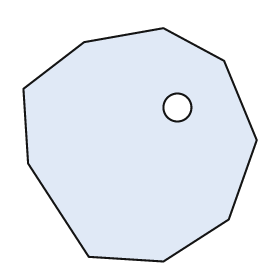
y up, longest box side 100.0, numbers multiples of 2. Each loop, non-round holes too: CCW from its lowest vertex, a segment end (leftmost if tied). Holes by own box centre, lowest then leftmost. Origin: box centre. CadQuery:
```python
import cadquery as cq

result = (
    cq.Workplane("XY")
    .moveTo(10.0, -50.0)
    .lineTo(38.0, -32.0)
    .lineTo(50.0, 2.0)
    .lineTo(36.0, 36.0)
    .lineTo(10.0, 50.0)
    .lineTo(-24.0, 44.0)
    .lineTo(-50.0, 24.0)
    .lineTo(-48.0, -8.0)
    .lineTo(-22.0, -48.0)
    .close()
    .moveTo(16.0, 16.0)
    .circle(6.0)
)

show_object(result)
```